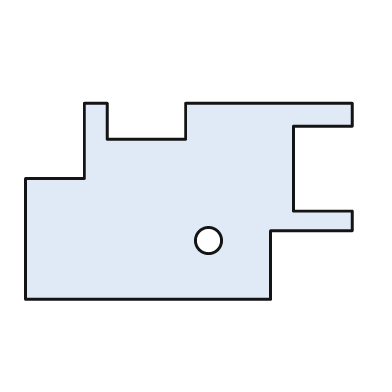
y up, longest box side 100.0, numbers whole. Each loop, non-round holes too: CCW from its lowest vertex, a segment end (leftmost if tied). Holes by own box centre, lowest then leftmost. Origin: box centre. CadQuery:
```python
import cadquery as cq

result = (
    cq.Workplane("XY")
    .moveTo(-50.0, -30.0)
    .lineTo(25.0, -30.0)
    .lineTo(25.0, -9.0)
    .lineTo(50.0, -9.0)
    .lineTo(50.0, -3.0)
    .lineTo(32.0, -3.0)
    .lineTo(32.0, 23.0)
    .lineTo(50.0, 23.0)
    .lineTo(50.0, 30.0)
    .lineTo(-1.0, 30.0)
    .lineTo(-1.0, 19.0)
    .lineTo(-25.0, 19.0)
    .lineTo(-25.0, 30.0)
    .lineTo(-32.0, 30.0)
    .lineTo(-32.0, 7.0)
    .lineTo(-50.0, 7.0)
    .close()
    .moveTo(6.0, -12.0)
    .circle(4.0)
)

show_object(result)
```